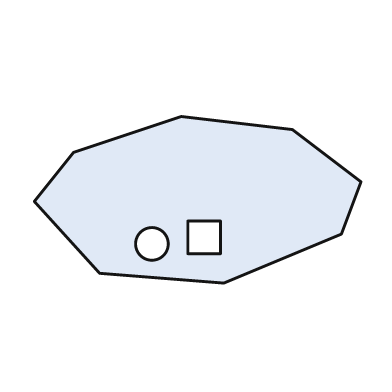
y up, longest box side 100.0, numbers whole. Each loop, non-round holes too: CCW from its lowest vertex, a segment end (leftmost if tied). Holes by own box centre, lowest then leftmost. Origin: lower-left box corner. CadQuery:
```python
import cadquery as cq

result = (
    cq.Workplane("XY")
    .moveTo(58.0, 0.0)
    .lineTo(94.0, 15.0)
    .lineTo(100.0, 31.0)
    .lineTo(79.0, 47.0)
    .lineTo(45.0, 51.0)
    .lineTo(12.0, 40.0)
    .lineTo(0.0, 25.0)
    .lineTo(20.0, 3.0)
    .close()
    .moveTo(36.0, 12.0)
    .circle(5.0)
    .moveTo(47.0, 9.0)
    .lineTo(57.0, 9.0)
    .lineTo(57.0, 19.0)
    .lineTo(47.0, 19.0)
    .close()
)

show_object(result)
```